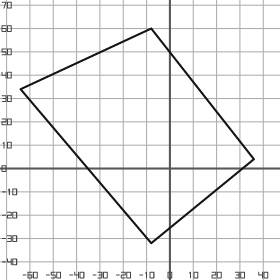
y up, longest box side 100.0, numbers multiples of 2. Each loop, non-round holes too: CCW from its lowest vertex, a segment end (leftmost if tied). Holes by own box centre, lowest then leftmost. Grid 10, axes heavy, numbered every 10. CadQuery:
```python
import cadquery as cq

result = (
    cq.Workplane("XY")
    .moveTo(-8.0, -32.0)
    .lineTo(36.0, 4.0)
    .lineTo(-8.0, 60.0)
    .lineTo(-64.0, 34.0)
    .close()
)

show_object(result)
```